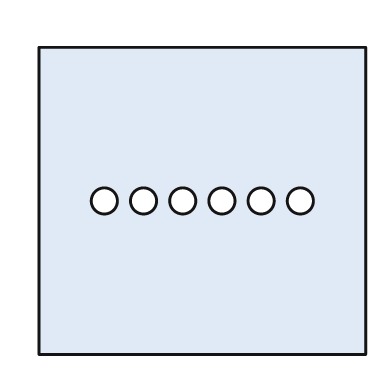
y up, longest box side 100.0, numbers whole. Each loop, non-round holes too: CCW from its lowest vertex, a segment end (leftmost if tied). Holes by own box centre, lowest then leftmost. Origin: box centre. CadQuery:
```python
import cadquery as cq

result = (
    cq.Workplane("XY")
    .moveTo(-50.0, -47.0)
    .lineTo(50.0, -47.0)
    .lineTo(50.0, 47.0)
    .lineTo(-50.0, 47.0)
    .close()
    .moveTo(-30.0, 0.0)
    .circle(4.0)
    .moveTo(-18.0, 0.0)
    .circle(4.0)
    .moveTo(-6.0, 0.0)
    .circle(4.0)
    .moveTo(6.0, 0.0)
    .circle(4.0)
    .moveTo(18.0, 0.0)
    .circle(4.0)
    .moveTo(30.0, 0.0)
    .circle(4.0)
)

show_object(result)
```